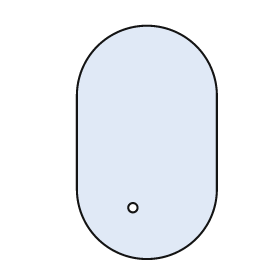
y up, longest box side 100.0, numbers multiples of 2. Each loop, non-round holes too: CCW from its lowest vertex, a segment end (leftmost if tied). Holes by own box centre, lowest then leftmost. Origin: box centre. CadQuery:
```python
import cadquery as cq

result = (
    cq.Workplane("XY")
    .moveTo(-30.0, -20.0)
    .threePointArc((0.0, -50.0), (30.0, -20.0))
    .lineTo(30.0, 20.0)
    .threePointArc((0.0, 50.0), (-30.0, 20.0))
    .close()
    .moveTo(-6.0, -28.0)
    .circle(2.0)
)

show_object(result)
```